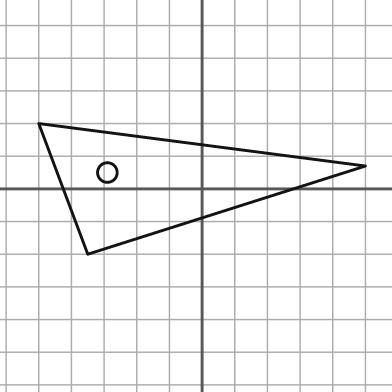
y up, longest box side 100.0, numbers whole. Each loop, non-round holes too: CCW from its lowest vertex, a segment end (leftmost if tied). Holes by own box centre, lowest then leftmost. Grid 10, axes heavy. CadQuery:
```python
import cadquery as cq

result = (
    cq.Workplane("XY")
    .moveTo(-35.0, -20.0)
    .lineTo(50.0, 7.0)
    .lineTo(-50.0, 20.0)
    .close()
    .moveTo(-29.0, 5.0)
    .circle(3.0)
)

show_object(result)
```